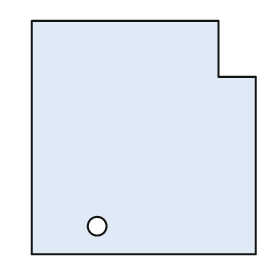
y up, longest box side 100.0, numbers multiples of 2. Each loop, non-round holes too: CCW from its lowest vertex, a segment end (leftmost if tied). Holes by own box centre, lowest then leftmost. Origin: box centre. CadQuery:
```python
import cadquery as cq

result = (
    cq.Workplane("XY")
    .moveTo(-48.0, -50.0)
    .lineTo(48.0, -50.0)
    .lineTo(48.0, 26.0)
    .lineTo(32.0, 26.0)
    .lineTo(32.0, 50.0)
    .lineTo(-48.0, 50.0)
    .close()
    .moveTo(-20.0, -38.0)
    .circle(4.0)
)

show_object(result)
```